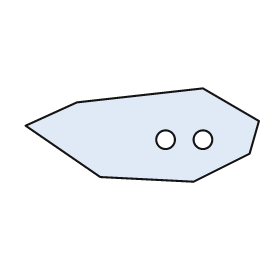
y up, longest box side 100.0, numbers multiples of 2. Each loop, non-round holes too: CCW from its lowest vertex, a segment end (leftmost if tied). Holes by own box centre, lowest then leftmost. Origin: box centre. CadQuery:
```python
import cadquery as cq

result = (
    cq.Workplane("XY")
    .moveTo(22.0, -20.0)
    .lineTo(46.0, -8.0)
    .lineTo(50.0, 6.0)
    .lineTo(26.0, 20.0)
    .lineTo(-28.0, 14.0)
    .lineTo(-50.0, 4.0)
    .lineTo(-18.0, -18.0)
    .close()
    .moveTo(10.0, -2.0)
    .circle(4.0)
    .moveTo(26.0, -2.0)
    .circle(4.0)
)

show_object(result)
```